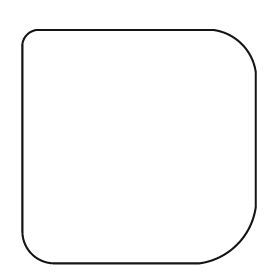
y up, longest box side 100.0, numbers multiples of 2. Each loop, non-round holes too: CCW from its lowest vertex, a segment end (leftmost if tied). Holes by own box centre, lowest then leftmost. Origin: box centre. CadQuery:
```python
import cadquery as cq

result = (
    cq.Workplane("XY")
    .moveTo(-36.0, -50.0)
    .lineTo(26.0, -50.0)
    .threePointArc((42.0, -42.0), (50.0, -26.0))
    .lineTo(50.0, 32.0)
    .threePointArc((44.0, 44.0), (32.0, 50.0))
    .lineTo(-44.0, 50.0)
    .threePointArc((-48.0, 48.0), (-50.0, 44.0))
    .lineTo(-50.0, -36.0)
    .threePointArc((-46.0, -46.0), (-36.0, -50.0))
    .close()
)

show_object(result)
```